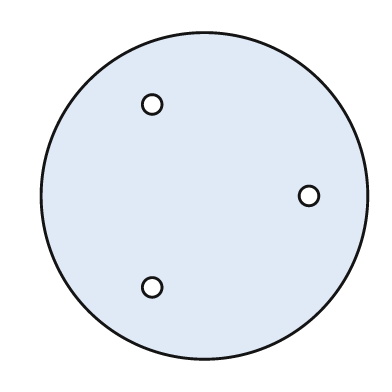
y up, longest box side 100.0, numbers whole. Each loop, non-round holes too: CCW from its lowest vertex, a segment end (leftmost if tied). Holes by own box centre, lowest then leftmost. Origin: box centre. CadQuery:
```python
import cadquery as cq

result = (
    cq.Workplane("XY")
    .moveTo(0.0, 0.0)
    .circle(50.0)
    .moveTo(-16.0, -28.0)
    .circle(3.0)
    .moveTo(32.0, 0.0)
    .circle(3.0)
    .moveTo(-16.0, 28.0)
    .circle(3.0)
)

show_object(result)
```